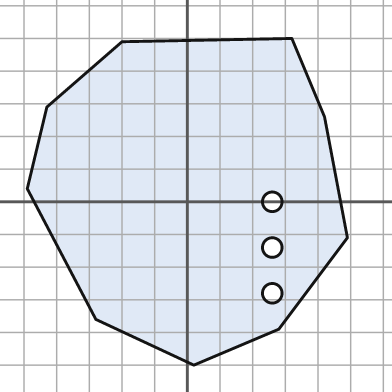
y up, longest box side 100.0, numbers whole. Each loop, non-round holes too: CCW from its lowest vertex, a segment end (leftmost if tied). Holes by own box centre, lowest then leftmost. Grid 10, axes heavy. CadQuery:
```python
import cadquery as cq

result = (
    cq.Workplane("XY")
    .moveTo(2.0, -50.0)
    .lineTo(28.0, -39.0)
    .lineTo(49.0, -11.0)
    .lineTo(42.0, 26.0)
    .lineTo(32.0, 50.0)
    .lineTo(-20.0, 49.0)
    .lineTo(-43.0, 29.0)
    .lineTo(-49.0, 4.0)
    .lineTo(-28.0, -36.0)
    .close()
    .moveTo(26.0, -28.0)
    .circle(3.0)
    .moveTo(26.0, -14.0)
    .circle(3.0)
    .moveTo(26.0, 0.0)
    .circle(3.0)
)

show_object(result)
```